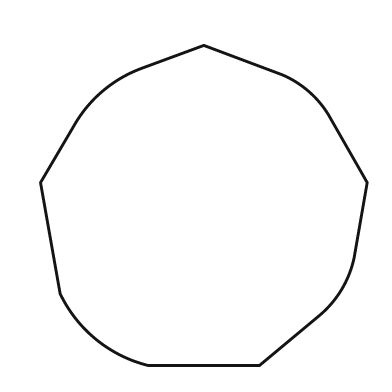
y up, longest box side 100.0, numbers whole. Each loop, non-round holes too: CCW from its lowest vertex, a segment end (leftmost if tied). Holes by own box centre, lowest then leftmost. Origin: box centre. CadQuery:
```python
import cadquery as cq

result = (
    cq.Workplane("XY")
    .moveTo(-17.0, -49.0)
    .lineTo(17.0, -49.0)
    .lineTo(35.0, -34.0)
    .threePointArc((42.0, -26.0), (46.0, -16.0))
    .lineTo(50.0, 7.0)
    .lineTo(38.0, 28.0)
    .threePointArc((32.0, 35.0), (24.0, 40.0))
    .lineTo(0.0, 49.0)
    .lineTo(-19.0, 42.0)
    .threePointArc((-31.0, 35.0), (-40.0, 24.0))
    .lineTo(-50.0, 7.0)
    .lineTo(-44.0, -27.0)
    .threePointArc((-33.0, -41.0), (-17.0, -49.0))
    .close()
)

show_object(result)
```